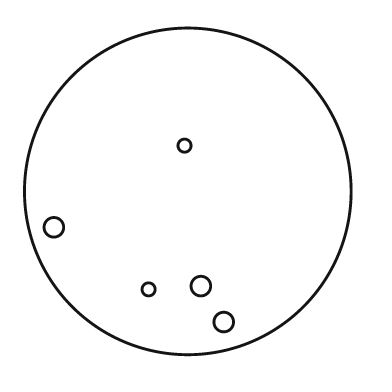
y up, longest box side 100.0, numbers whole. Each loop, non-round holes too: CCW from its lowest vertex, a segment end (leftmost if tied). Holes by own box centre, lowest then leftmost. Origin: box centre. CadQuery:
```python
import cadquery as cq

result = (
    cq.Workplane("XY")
    .moveTo(0.0, 0.0)
    .circle(50.0)
    .moveTo(11.0, -40.0)
    .circle(3.0)
    .moveTo(-12.0, -30.0)
    .circle(2.0)
    .moveTo(4.0, -29.0)
    .circle(3.0)
    .moveTo(-41.0, -11.0)
    .circle(3.0)
    .moveTo(-1.0, 14.0)
    .circle(2.0)
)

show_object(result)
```